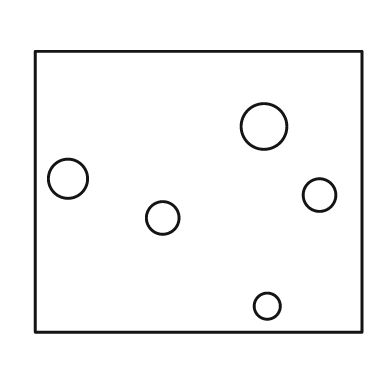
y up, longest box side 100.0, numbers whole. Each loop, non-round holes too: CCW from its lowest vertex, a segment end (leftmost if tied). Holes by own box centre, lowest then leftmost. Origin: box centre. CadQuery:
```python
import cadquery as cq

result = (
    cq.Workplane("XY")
    .moveTo(-50.0, -43.0)
    .lineTo(50.0, -43.0)
    .lineTo(50.0, 43.0)
    .lineTo(-50.0, 43.0)
    .close()
    .moveTo(21.0, -35.0)
    .circle(4.0)
    .moveTo(-11.0, -8.0)
    .circle(5.0)
    .moveTo(37.0, -1.0)
    .circle(5.0)
    .moveTo(-40.0, 4.0)
    .circle(6.0)
    .moveTo(20.0, 20.0)
    .circle(7.0)
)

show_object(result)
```